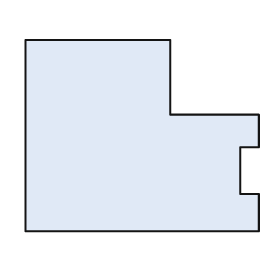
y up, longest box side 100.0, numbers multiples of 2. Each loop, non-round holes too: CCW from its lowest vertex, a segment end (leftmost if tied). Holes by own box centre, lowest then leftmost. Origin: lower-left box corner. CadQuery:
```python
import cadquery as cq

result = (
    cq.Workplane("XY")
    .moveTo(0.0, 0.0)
    .lineTo(100.0, 0.0)
    .lineTo(100.0, 16.0)
    .lineTo(92.0, 16.0)
    .lineTo(92.0, 36.0)
    .lineTo(100.0, 36.0)
    .lineTo(100.0, 50.0)
    .lineTo(62.0, 50.0)
    .lineTo(62.0, 82.0)
    .lineTo(0.0, 82.0)
    .close()
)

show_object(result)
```